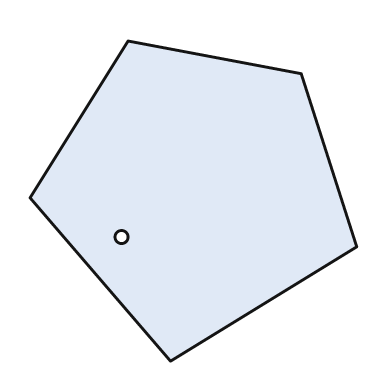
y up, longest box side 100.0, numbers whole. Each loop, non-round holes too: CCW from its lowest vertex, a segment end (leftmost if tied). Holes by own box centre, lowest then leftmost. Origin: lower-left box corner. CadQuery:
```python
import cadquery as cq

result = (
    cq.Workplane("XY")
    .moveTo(43.0, 0.0)
    .lineTo(100.0, 35.0)
    .lineTo(83.0, 88.0)
    .lineTo(30.0, 98.0)
    .lineTo(0.0, 50.0)
    .close()
    .moveTo(28.0, 38.0)
    .circle(2.0)
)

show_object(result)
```